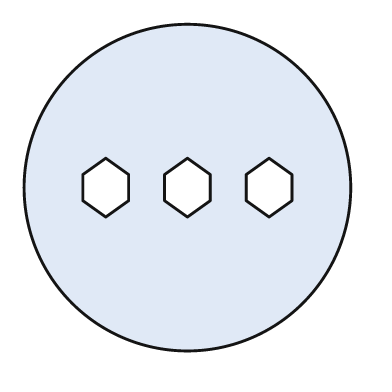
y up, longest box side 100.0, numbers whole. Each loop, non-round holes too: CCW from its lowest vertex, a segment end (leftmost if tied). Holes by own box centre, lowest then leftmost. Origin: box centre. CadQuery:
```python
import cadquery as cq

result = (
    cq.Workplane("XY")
    .moveTo(0.0, 0.0)
    .circle(50.0)
    .moveTo(-25.0, -9.0)
    .lineTo(-18.0, -4.0)
    .lineTo(-18.0, 4.0)
    .lineTo(-25.0, 9.0)
    .lineTo(-32.0, 4.0)
    .lineTo(-32.0, -4.0)
    .close()
    .moveTo(0.0, -9.0)
    .lineTo(7.0, -4.0)
    .lineTo(7.0, 4.0)
    .lineTo(0.0, 9.0)
    .lineTo(-7.0, 4.0)
    .lineTo(-7.0, -4.0)
    .close()
    .moveTo(25.0, -9.0)
    .lineTo(32.0, -4.0)
    .lineTo(32.0, 4.0)
    .lineTo(25.0, 9.0)
    .lineTo(18.0, 4.0)
    .lineTo(18.0, -4.0)
    .close()
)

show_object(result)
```